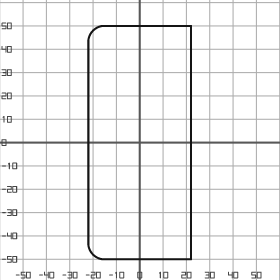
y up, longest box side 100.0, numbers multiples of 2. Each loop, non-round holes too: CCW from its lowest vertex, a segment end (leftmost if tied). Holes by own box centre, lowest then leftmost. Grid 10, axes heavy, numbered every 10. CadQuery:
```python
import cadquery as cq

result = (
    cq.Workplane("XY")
    .moveTo(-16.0, -50.0)
    .lineTo(22.0, -50.0)
    .lineTo(22.0, 50.0)
    .lineTo(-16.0, 50.0)
    .threePointArc((-20.0, 48.0), (-22.0, 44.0))
    .lineTo(-22.0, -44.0)
    .threePointArc((-20.0, -48.0), (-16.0, -50.0))
    .close()
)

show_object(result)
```